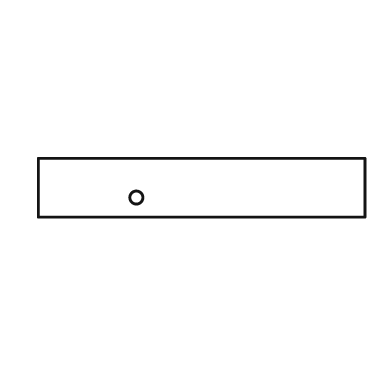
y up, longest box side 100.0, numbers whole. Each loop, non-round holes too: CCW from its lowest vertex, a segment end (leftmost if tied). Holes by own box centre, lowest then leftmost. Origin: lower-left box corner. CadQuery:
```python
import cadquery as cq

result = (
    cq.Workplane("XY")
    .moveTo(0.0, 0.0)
    .lineTo(100.0, 0.0)
    .lineTo(100.0, 18.0)
    .lineTo(0.0, 18.0)
    .close()
    .moveTo(30.0, 6.0)
    .circle(2.0)
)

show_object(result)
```